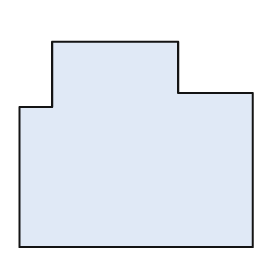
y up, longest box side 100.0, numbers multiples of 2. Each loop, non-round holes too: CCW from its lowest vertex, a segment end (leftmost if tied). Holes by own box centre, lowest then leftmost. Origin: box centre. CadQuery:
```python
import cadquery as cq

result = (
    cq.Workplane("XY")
    .moveTo(-50.0, -44.0)
    .lineTo(50.0, -44.0)
    .lineTo(50.0, 22.0)
    .lineTo(18.0, 22.0)
    .lineTo(18.0, 44.0)
    .lineTo(-36.0, 44.0)
    .lineTo(-36.0, 16.0)
    .lineTo(-50.0, 16.0)
    .close()
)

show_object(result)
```